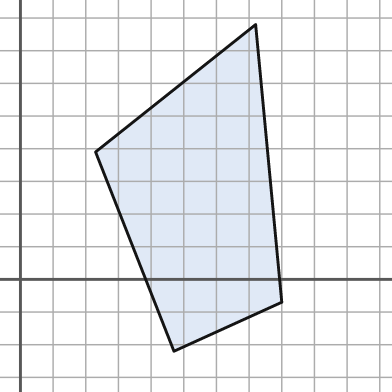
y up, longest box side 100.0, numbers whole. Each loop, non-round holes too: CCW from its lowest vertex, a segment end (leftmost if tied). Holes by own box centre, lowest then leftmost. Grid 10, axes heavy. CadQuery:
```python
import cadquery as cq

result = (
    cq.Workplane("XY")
    .moveTo(47.0, -22.0)
    .lineTo(80.0, -7.0)
    .lineTo(72.0, 78.0)
    .lineTo(23.0, 39.0)
    .close()
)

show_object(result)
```